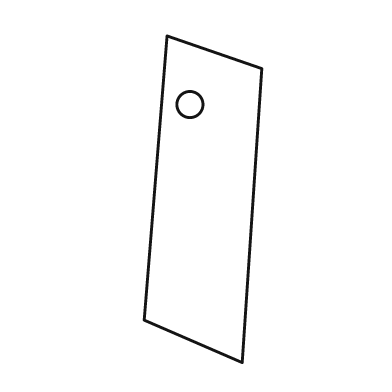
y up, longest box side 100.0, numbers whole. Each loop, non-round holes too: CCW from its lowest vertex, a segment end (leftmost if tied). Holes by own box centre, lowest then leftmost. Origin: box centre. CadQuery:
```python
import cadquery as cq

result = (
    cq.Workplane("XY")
    .moveTo(12.0, -50.0)
    .lineTo(18.0, 40.0)
    .lineTo(-11.0, 50.0)
    .lineTo(-18.0, -37.0)
    .close()
    .moveTo(-4.0, 29.0)
    .circle(4.0)
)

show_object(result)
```